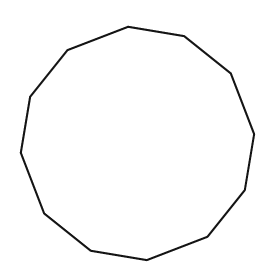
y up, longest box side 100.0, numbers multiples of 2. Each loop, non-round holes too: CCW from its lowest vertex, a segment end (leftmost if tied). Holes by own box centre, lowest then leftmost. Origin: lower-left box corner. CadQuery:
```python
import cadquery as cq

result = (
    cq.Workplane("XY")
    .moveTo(54.0, 0.0)
    .lineTo(80.0, 10.0)
    .lineTo(96.0, 30.0)
    .lineTo(100.0, 54.0)
    .lineTo(90.0, 80.0)
    .lineTo(70.0, 96.0)
    .lineTo(46.0, 100.0)
    .lineTo(20.0, 90.0)
    .lineTo(4.0, 70.0)
    .lineTo(0.0, 46.0)
    .lineTo(10.0, 20.0)
    .lineTo(30.0, 4.0)
    .close()
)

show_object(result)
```